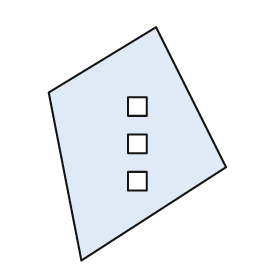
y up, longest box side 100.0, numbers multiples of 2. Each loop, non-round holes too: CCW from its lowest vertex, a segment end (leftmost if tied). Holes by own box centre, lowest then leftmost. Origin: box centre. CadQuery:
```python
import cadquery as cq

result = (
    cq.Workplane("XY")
    .moveTo(-24.0, -50.0)
    .lineTo(38.0, -10.0)
    .lineTo(8.0, 50.0)
    .lineTo(-38.0, 22.0)
    .close()
    .moveTo(-4.0, -20.0)
    .lineTo(4.0, -20.0)
    .lineTo(4.0, -12.0)
    .lineTo(-4.0, -12.0)
    .close()
    .moveTo(-4.0, -4.0)
    .lineTo(4.0, -4.0)
    .lineTo(4.0, 4.0)
    .lineTo(-4.0, 4.0)
    .close()
    .moveTo(-4.0, 12.0)
    .lineTo(4.0, 12.0)
    .lineTo(4.0, 20.0)
    .lineTo(-4.0, 20.0)
    .close()
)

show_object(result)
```